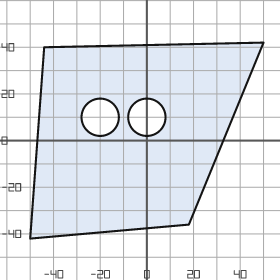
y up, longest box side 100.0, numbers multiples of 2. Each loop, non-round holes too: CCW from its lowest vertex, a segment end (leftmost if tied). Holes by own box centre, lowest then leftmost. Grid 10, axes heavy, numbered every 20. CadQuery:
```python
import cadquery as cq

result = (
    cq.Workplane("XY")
    .moveTo(-50.0, -42.0)
    .lineTo(18.0, -36.0)
    .lineTo(50.0, 42.0)
    .lineTo(-44.0, 40.0)
    .close()
    .moveTo(-20.0, 10.0)
    .circle(8.0)
    .moveTo(0.0, 10.0)
    .circle(8.0)
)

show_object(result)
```